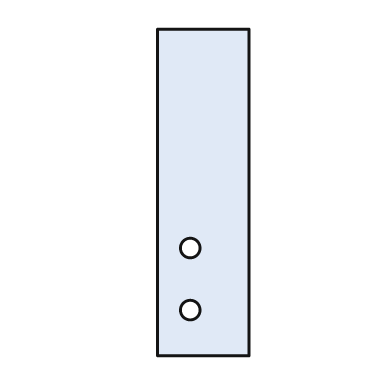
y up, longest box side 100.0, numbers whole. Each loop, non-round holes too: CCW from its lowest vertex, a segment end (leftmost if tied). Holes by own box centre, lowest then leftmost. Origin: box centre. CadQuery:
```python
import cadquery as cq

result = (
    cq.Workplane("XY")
    .moveTo(-14.0, -50.0)
    .lineTo(14.0, -50.0)
    .lineTo(14.0, 50.0)
    .lineTo(-14.0, 50.0)
    .close()
    .moveTo(-4.0, -36.0)
    .circle(3.0)
    .moveTo(-4.0, -17.0)
    .circle(3.0)
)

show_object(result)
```